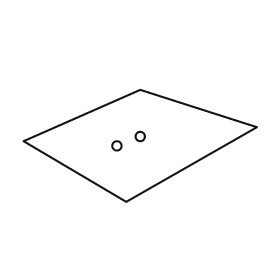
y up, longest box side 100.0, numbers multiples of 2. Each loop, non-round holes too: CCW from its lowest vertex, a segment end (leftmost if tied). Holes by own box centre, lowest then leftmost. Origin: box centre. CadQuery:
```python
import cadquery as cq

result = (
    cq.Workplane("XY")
    .moveTo(-6.0, -24.0)
    .lineTo(50.0, 8.0)
    .lineTo(0.0, 24.0)
    .lineTo(-50.0, 2.0)
    .close()
    .moveTo(-10.0, 0.0)
    .circle(2.0)
    .moveTo(0.0, 4.0)
    .circle(2.0)
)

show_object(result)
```